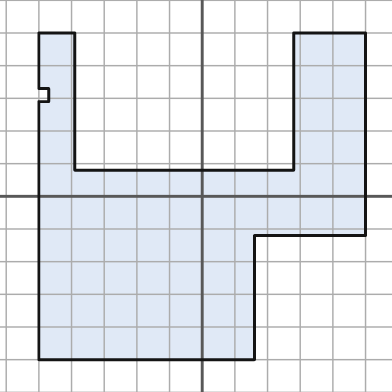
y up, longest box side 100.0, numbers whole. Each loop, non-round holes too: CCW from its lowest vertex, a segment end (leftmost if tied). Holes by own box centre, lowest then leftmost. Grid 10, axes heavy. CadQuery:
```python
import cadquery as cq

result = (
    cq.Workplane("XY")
    .moveTo(-50.0, -50.0)
    .lineTo(16.0, -50.0)
    .lineTo(16.0, -12.0)
    .lineTo(50.0, -12.0)
    .lineTo(50.0, 50.0)
    .lineTo(28.0, 50.0)
    .lineTo(28.0, 8.0)
    .lineTo(-39.0, 8.0)
    .lineTo(-39.0, 50.0)
    .lineTo(-50.0, 50.0)
    .lineTo(-50.0, 33.0)
    .lineTo(-47.0, 33.0)
    .lineTo(-47.0, 29.0)
    .lineTo(-50.0, 29.0)
    .close()
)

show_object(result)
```